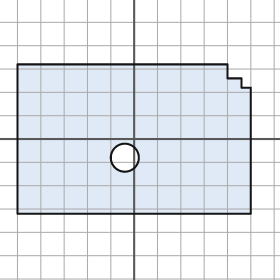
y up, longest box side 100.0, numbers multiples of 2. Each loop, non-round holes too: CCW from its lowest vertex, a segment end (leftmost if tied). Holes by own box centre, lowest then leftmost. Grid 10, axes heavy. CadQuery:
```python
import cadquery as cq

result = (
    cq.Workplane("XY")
    .moveTo(-50.0, -32.0)
    .lineTo(50.0, -32.0)
    .lineTo(50.0, 22.0)
    .lineTo(46.0, 22.0)
    .lineTo(46.0, 26.0)
    .lineTo(40.0, 26.0)
    .lineTo(40.0, 32.0)
    .lineTo(-50.0, 32.0)
    .close()
    .moveTo(-4.0, -8.0)
    .circle(6.0)
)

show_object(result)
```